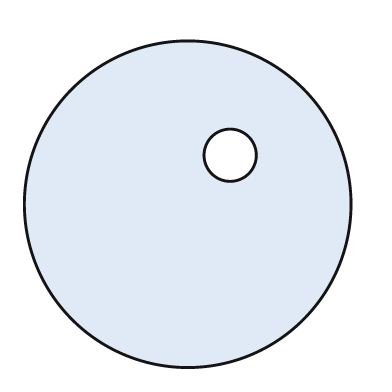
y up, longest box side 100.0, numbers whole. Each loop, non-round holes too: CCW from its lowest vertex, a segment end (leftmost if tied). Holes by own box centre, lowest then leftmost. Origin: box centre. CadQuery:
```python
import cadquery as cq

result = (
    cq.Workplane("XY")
    .moveTo(0.0, 0.0)
    .circle(50.0)
    .moveTo(13.0, 15.0)
    .circle(8.0)
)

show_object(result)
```